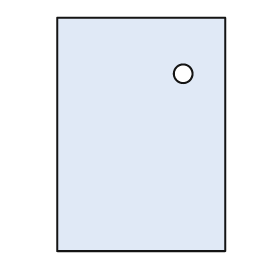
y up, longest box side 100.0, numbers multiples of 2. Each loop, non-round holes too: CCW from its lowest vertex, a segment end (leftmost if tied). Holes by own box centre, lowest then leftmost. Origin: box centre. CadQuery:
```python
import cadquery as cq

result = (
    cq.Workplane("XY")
    .moveTo(-36.0, -50.0)
    .lineTo(36.0, -50.0)
    .lineTo(36.0, 50.0)
    .lineTo(-36.0, 50.0)
    .close()
    .moveTo(18.0, 26.0)
    .circle(4.0)
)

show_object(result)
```